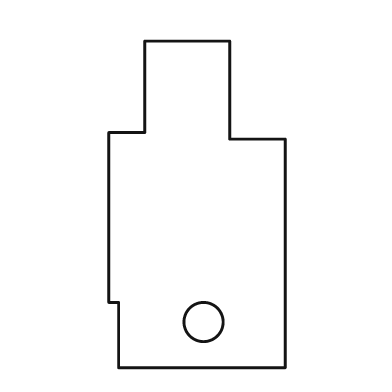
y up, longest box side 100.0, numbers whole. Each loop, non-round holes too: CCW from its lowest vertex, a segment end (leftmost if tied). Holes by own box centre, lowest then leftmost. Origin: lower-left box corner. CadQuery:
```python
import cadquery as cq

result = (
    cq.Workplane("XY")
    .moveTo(3.0, 0.0)
    .lineTo(54.0, 0.0)
    .lineTo(54.0, 70.0)
    .lineTo(37.0, 70.0)
    .lineTo(37.0, 100.0)
    .lineTo(11.0, 100.0)
    .lineTo(11.0, 72.0)
    .lineTo(0.0, 72.0)
    .lineTo(0.0, 20.0)
    .lineTo(3.0, 20.0)
    .close()
    .moveTo(29.0, 14.0)
    .circle(6.0)
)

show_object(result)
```